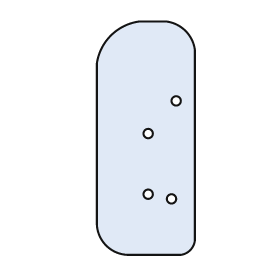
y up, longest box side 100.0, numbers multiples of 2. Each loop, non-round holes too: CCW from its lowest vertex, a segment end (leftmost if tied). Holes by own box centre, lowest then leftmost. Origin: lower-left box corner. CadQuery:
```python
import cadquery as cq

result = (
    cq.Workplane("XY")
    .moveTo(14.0, 0.0)
    .lineTo(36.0, 0.0)
    .threePointArc((40.0, 2.0), (42.0, 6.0))
    .lineTo(42.0, 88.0)
    .threePointArc((38.0, 96.0), (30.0, 100.0))
    .lineTo(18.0, 100.0)
    .threePointArc((6.0, 94.0), (0.0, 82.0))
    .lineTo(0.0, 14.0)
    .threePointArc((4.0, 4.0), (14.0, 0.0))
    .close()
    .moveTo(32.0, 24.0)
    .circle(2.0)
    .moveTo(22.0, 26.0)
    .circle(2.0)
    .moveTo(22.0, 52.0)
    .circle(2.0)
    .moveTo(34.0, 66.0)
    .circle(2.0)
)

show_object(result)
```